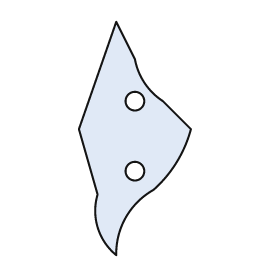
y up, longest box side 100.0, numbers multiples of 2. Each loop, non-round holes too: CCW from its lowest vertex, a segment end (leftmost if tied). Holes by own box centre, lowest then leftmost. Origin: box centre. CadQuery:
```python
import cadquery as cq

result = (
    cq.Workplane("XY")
    .moveTo(-8.0, -50.0)
    .threePointArc((-4.0, -34.0), (8.0, -22.0))
    .threePointArc((18.0, -10.0), (24.0, 4.0))
    .lineTo(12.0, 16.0)
    .threePointArc((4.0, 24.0), (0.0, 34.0))
    .lineTo(-8.0, 50.0)
    .lineTo(-24.0, 4.0)
    .lineTo(-16.0, -24.0)
    .threePointArc((-16.0, -38.0), (-8.0, -50.0))
    .close()
    .moveTo(0.0, -14.0)
    .circle(4.0)
    .moveTo(0.0, 16.0)
    .circle(4.0)
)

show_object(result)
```